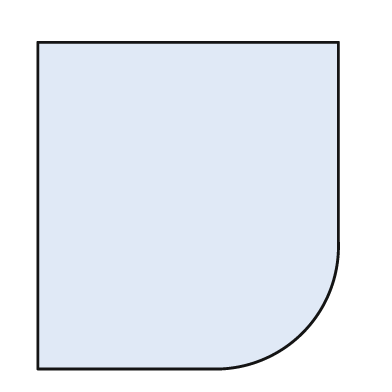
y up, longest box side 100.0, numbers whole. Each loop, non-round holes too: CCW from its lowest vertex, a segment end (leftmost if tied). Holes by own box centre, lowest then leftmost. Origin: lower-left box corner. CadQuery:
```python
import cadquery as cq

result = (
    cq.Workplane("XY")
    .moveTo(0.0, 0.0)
    .lineTo(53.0, 0.0)
    .threePointArc((81.0, 11.0), (92.0, 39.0))
    .lineTo(92.0, 100.0)
    .lineTo(0.0, 100.0)
    .close()
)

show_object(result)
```